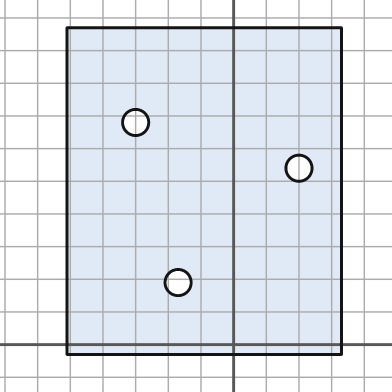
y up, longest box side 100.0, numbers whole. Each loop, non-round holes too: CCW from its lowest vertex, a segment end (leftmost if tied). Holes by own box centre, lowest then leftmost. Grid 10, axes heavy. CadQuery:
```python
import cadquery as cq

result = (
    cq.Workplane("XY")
    .moveTo(-51.0, -3.0)
    .lineTo(33.0, -3.0)
    .lineTo(33.0, 97.0)
    .lineTo(-51.0, 97.0)
    .close()
    .moveTo(-17.0, 19.0)
    .circle(4.0)
    .moveTo(20.0, 54.0)
    .circle(4.0)
    .moveTo(-30.0, 68.0)
    .circle(4.0)
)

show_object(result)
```